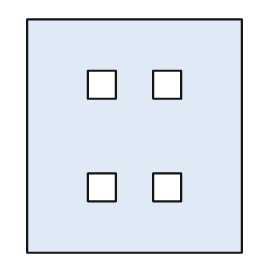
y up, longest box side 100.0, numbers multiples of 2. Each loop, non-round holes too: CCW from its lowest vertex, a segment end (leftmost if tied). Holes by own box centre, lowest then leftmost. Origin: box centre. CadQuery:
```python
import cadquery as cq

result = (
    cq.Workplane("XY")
    .moveTo(-46.0, -50.0)
    .lineTo(46.0, -50.0)
    .lineTo(46.0, 50.0)
    .lineTo(-46.0, 50.0)
    .close()
    .moveTo(-20.0, -28.0)
    .lineTo(-8.0, -28.0)
    .lineTo(-8.0, -16.0)
    .lineTo(-20.0, -16.0)
    .close()
    .moveTo(8.0, -28.0)
    .lineTo(20.0, -28.0)
    .lineTo(20.0, -16.0)
    .lineTo(8.0, -16.0)
    .close()
    .moveTo(-20.0, 16.0)
    .lineTo(-8.0, 16.0)
    .lineTo(-8.0, 28.0)
    .lineTo(-20.0, 28.0)
    .close()
    .moveTo(8.0, 16.0)
    .lineTo(20.0, 16.0)
    .lineTo(20.0, 28.0)
    .lineTo(8.0, 28.0)
    .close()
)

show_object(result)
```